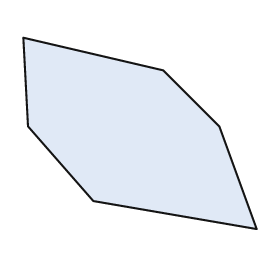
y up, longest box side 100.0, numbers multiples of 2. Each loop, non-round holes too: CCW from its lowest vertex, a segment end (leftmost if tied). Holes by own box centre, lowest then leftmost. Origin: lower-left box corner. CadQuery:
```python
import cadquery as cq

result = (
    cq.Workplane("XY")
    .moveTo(100.0, 0.0)
    .lineTo(84.0, 44.0)
    .lineTo(60.0, 68.0)
    .lineTo(0.0, 82.0)
    .lineTo(2.0, 44.0)
    .lineTo(30.0, 12.0)
    .close()
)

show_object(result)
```